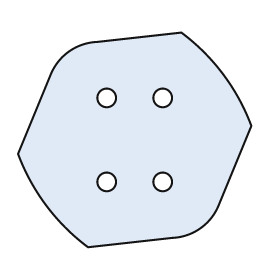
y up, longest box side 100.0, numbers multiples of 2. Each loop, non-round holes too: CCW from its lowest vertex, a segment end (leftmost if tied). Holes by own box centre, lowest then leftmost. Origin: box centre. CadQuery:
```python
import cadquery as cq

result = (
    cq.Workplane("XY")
    .moveTo(-20.0, -46.0)
    .lineTo(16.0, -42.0)
    .threePointArc((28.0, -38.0), (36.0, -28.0))
    .lineTo(50.0, 6.0)
    .threePointArc((38.0, 28.0), (20.0, 46.0))
    .lineTo(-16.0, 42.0)
    .threePointArc((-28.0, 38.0), (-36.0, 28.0))
    .lineTo(-50.0, -6.0)
    .threePointArc((-38.0, -28.0), (-20.0, -46.0))
    .close()
    .moveTo(-12.0, -18.0)
    .circle(4.0)
    .moveTo(12.0, -18.0)
    .circle(4.0)
    .moveTo(-12.0, 18.0)
    .circle(4.0)
    .moveTo(12.0, 18.0)
    .circle(4.0)
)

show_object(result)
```